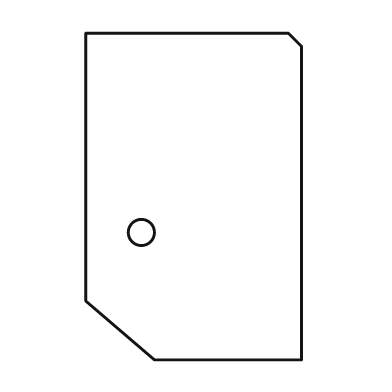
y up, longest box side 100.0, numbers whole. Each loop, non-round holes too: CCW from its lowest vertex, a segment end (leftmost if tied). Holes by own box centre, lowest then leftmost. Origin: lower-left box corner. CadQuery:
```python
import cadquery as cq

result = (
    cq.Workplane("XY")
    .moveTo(21.0, 0.0)
    .lineTo(66.0, 0.0)
    .lineTo(66.0, 96.0)
    .lineTo(62.0, 100.0)
    .lineTo(0.0, 100.0)
    .lineTo(0.0, 18.0)
    .close()
    .moveTo(17.0, 39.0)
    .circle(4.0)
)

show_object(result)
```